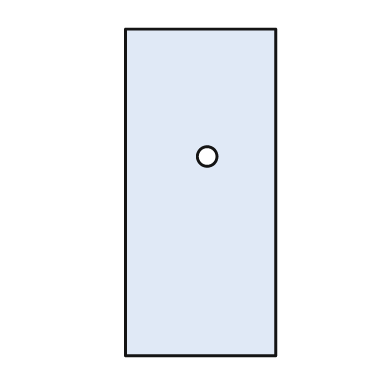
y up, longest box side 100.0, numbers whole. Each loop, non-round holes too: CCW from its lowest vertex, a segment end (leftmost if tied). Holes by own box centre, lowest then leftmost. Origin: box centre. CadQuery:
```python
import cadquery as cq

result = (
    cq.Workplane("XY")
    .moveTo(-23.0, -50.0)
    .lineTo(23.0, -50.0)
    .lineTo(23.0, 50.0)
    .lineTo(-23.0, 50.0)
    .close()
    .moveTo(2.0, 11.0)
    .circle(3.0)
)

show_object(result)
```